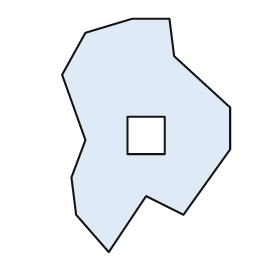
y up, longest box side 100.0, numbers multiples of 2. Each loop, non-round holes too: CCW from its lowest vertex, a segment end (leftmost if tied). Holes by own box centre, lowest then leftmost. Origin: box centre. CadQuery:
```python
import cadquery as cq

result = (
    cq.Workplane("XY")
    .moveTo(-16.0, -50.0)
    .lineTo(0.0, -26.0)
    .lineTo(16.0, -34.0)
    .lineTo(36.0, -6.0)
    .lineTo(36.0, 12.0)
    .lineTo(12.0, 34.0)
    .lineTo(10.0, 50.0)
    .lineTo(-6.0, 50.0)
    .lineTo(-26.0, 44.0)
    .lineTo(-36.0, 26.0)
    .lineTo(-26.0, -2.0)
    .lineTo(-32.0, -18.0)
    .lineTo(-30.0, -34.0)
    .close()
    .moveTo(-8.0, -8.0)
    .lineTo(8.0, -8.0)
    .lineTo(8.0, 8.0)
    .lineTo(-8.0, 8.0)
    .close()
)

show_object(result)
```